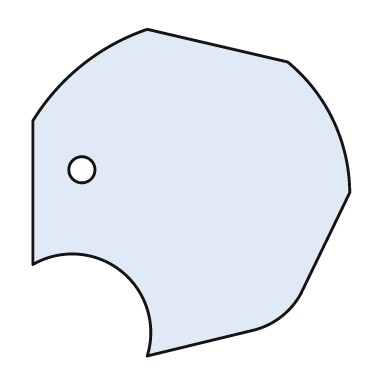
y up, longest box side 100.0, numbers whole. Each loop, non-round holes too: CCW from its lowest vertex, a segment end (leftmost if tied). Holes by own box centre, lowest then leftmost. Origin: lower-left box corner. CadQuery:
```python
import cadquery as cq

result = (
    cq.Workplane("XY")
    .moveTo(35.0, 0.0)
    .lineTo(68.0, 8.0)
    .threePointArc((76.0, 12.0), (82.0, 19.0))
    .lineTo(97.0, 50.0)
    .threePointArc((92.0, 72.0), (78.0, 90.0))
    .lineTo(35.0, 100.0)
    .threePointArc((15.0, 89.0), (0.0, 72.0))
    .lineTo(0.0, 28.0)
    .threePointArc((27.0, 26.0), (35.0, 0.0))
    .close()
    .moveTo(15.0, 57.0)
    .circle(4.0)
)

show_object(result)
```